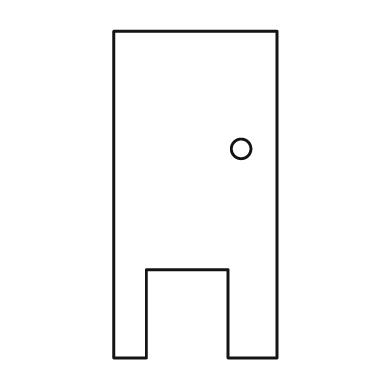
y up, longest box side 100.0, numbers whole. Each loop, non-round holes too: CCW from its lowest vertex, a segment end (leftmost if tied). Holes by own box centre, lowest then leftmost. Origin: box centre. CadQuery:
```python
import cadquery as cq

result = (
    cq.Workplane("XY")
    .moveTo(-25.0, -50.0)
    .lineTo(-15.0, -50.0)
    .lineTo(-15.0, -23.0)
    .lineTo(10.0, -23.0)
    .lineTo(10.0, -50.0)
    .lineTo(25.0, -50.0)
    .lineTo(25.0, 50.0)
    .lineTo(-25.0, 50.0)
    .close()
    .moveTo(14.0, 14.0)
    .circle(3.0)
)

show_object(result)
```